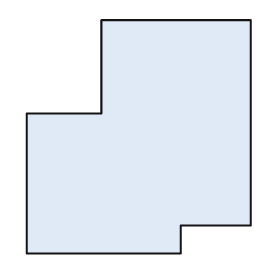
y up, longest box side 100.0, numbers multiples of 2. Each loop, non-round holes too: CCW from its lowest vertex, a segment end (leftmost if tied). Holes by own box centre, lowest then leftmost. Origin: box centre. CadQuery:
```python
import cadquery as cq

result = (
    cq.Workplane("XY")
    .moveTo(-48.0, -50.0)
    .lineTo(18.0, -50.0)
    .lineTo(18.0, -38.0)
    .lineTo(48.0, -38.0)
    .lineTo(48.0, 50.0)
    .lineTo(-16.0, 50.0)
    .lineTo(-16.0, 10.0)
    .lineTo(-48.0, 10.0)
    .close()
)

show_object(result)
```